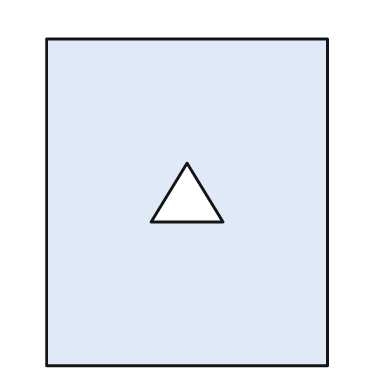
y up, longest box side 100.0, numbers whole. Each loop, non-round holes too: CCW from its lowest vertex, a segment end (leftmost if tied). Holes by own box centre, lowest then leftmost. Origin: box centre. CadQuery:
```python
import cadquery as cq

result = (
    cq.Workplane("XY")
    .moveTo(-43.0, -50.0)
    .lineTo(43.0, -50.0)
    .lineTo(43.0, 50.0)
    .lineTo(-43.0, 50.0)
    .close()
    .moveTo(-11.0, -6.0)
    .lineTo(11.0, -6.0)
    .lineTo(0.0, 12.0)
    .close()
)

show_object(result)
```